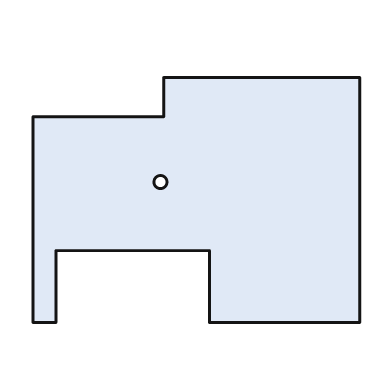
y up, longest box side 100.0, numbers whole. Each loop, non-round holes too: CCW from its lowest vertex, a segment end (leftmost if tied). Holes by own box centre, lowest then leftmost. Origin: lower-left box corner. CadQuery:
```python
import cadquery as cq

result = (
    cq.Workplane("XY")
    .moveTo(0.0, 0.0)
    .lineTo(7.0, 0.0)
    .lineTo(7.0, 22.0)
    .lineTo(54.0, 22.0)
    .lineTo(54.0, 0.0)
    .lineTo(100.0, 0.0)
    .lineTo(100.0, 75.0)
    .lineTo(40.0, 75.0)
    .lineTo(40.0, 63.0)
    .lineTo(0.0, 63.0)
    .close()
    .moveTo(39.0, 43.0)
    .circle(2.0)
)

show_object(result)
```